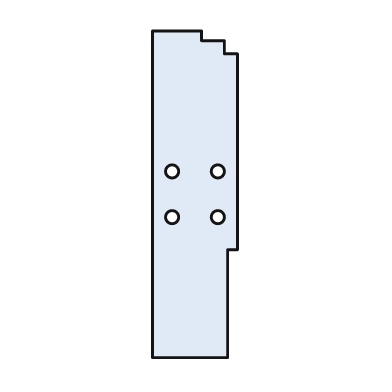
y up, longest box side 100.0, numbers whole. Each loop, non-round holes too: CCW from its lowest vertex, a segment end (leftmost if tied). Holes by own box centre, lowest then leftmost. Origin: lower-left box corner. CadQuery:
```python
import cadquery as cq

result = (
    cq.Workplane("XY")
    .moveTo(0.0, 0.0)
    .lineTo(23.0, 0.0)
    .lineTo(23.0, 33.0)
    .lineTo(26.0, 33.0)
    .lineTo(26.0, 93.0)
    .lineTo(22.0, 93.0)
    .lineTo(22.0, 97.0)
    .lineTo(15.0, 97.0)
    .lineTo(15.0, 100.0)
    .lineTo(0.0, 100.0)
    .close()
    .moveTo(6.0, 43.0)
    .circle(2.0)
    .moveTo(20.0, 43.0)
    .circle(2.0)
    .moveTo(6.0, 57.0)
    .circle(2.0)
    .moveTo(20.0, 57.0)
    .circle(2.0)
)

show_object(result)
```